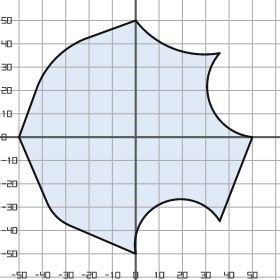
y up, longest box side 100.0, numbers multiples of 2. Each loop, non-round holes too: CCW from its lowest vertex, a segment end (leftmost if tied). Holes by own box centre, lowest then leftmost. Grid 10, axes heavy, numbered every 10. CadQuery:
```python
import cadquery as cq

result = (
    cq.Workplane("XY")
    .moveTo(0.0, -50.0)
    .threePointArc((12.0, -28.0), (36.0, -36.0))
    .lineTo(50.0, 0.0)
    .threePointArc((32.0, 14.0), (36.0, 36.0))
    .threePointArc((16.0, 38.0), (0.0, 50.0))
    .lineTo(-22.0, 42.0)
    .threePointArc((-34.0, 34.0), (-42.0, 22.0))
    .lineTo(-50.0, 0.0)
    .lineTo(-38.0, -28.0)
    .threePointArc((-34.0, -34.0), (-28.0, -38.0))
    .close()
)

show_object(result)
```